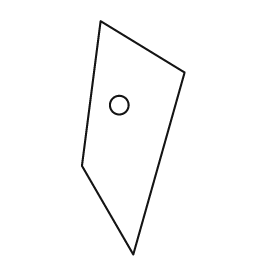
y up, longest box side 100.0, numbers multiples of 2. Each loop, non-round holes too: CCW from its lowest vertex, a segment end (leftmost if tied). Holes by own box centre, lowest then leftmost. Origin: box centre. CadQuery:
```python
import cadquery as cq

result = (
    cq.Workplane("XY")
    .moveTo(0.0, -50.0)
    .lineTo(22.0, 28.0)
    .lineTo(-14.0, 50.0)
    .lineTo(-22.0, -12.0)
    .close()
    .moveTo(-6.0, 14.0)
    .circle(4.0)
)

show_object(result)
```